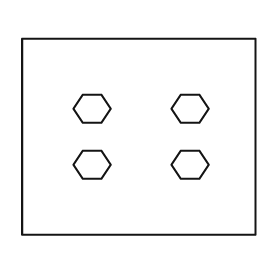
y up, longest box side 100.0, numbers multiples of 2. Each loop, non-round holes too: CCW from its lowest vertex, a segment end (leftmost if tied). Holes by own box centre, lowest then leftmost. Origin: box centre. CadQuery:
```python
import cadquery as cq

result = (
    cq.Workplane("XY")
    .moveTo(-50.0, -42.0)
    .lineTo(50.0, -42.0)
    .lineTo(50.0, 42.0)
    .lineTo(-50.0, 42.0)
    .close()
    .moveTo(-24.0, -18.0)
    .lineTo(-16.0, -18.0)
    .lineTo(-12.0, -12.0)
    .lineTo(-16.0, -6.0)
    .lineTo(-24.0, -6.0)
    .lineTo(-28.0, -12.0)
    .close()
    .moveTo(18.0, -18.0)
    .lineTo(26.0, -18.0)
    .lineTo(30.0, -12.0)
    .lineTo(26.0, -6.0)
    .lineTo(18.0, -6.0)
    .lineTo(14.0, -12.0)
    .close()
    .moveTo(-24.0, 6.0)
    .lineTo(-16.0, 6.0)
    .lineTo(-12.0, 12.0)
    .lineTo(-16.0, 18.0)
    .lineTo(-24.0, 18.0)
    .lineTo(-28.0, 12.0)
    .close()
    .moveTo(18.0, 6.0)
    .lineTo(26.0, 6.0)
    .lineTo(30.0, 12.0)
    .lineTo(26.0, 18.0)
    .lineTo(18.0, 18.0)
    .lineTo(14.0, 12.0)
    .close()
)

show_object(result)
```